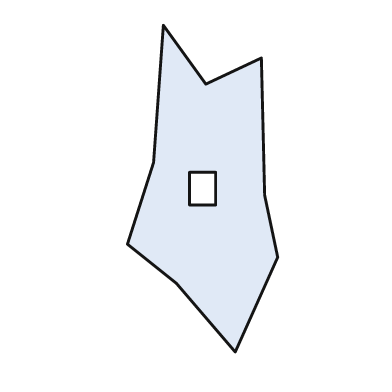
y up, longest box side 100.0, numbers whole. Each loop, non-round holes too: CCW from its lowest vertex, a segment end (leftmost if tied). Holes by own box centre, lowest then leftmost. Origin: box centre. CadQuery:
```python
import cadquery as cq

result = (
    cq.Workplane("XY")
    .moveTo(10.0, -50.0)
    .lineTo(23.0, -21.0)
    .lineTo(19.0, -2.0)
    .lineTo(18.0, 40.0)
    .lineTo(1.0, 32.0)
    .lineTo(-12.0, 50.0)
    .lineTo(-15.0, 8.0)
    .lineTo(-23.0, -17.0)
    .lineTo(-8.0, -29.0)
    .close()
    .moveTo(-4.0, -5.0)
    .lineTo(4.0, -5.0)
    .lineTo(4.0, 5.0)
    .lineTo(-4.0, 5.0)
    .close()
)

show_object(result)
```